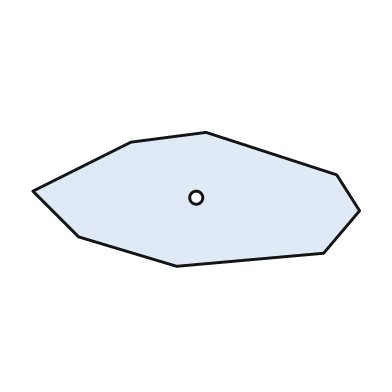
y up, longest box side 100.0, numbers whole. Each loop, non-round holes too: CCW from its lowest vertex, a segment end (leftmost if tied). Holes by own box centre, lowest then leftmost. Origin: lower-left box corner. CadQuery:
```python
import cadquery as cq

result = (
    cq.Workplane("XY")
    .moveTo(44.0, 0.0)
    .lineTo(89.0, 4.0)
    .lineTo(100.0, 17.0)
    .lineTo(93.0, 28.0)
    .lineTo(53.0, 41.0)
    .lineTo(30.0, 38.0)
    .lineTo(0.0, 23.0)
    .lineTo(14.0, 9.0)
    .close()
    .moveTo(50.0, 21.0)
    .circle(2.0)
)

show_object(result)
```